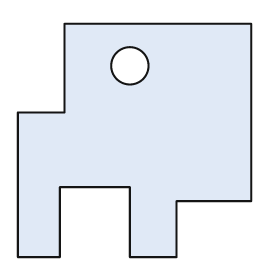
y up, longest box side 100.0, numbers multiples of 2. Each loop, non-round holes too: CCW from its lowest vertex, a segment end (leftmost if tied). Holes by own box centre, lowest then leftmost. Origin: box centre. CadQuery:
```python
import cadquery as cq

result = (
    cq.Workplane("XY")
    .moveTo(-50.0, -50.0)
    .lineTo(-32.0, -50.0)
    .lineTo(-32.0, -20.0)
    .lineTo(-2.0, -20.0)
    .lineTo(-2.0, -50.0)
    .lineTo(18.0, -50.0)
    .lineTo(18.0, -26.0)
    .lineTo(50.0, -26.0)
    .lineTo(50.0, 50.0)
    .lineTo(-30.0, 50.0)
    .lineTo(-30.0, 12.0)
    .lineTo(-50.0, 12.0)
    .close()
    .moveTo(-2.0, 32.0)
    .circle(8.0)
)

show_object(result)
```